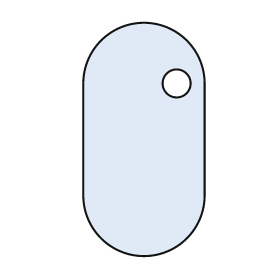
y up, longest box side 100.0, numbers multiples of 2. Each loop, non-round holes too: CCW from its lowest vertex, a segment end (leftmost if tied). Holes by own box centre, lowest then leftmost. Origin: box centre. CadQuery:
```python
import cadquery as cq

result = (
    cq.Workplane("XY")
    .moveTo(-26.0, -24.0)
    .threePointArc((0.0, -50.0), (26.0, -24.0))
    .lineTo(26.0, 24.0)
    .threePointArc((0.0, 50.0), (-26.0, 24.0))
    .close()
    .moveTo(14.0, 24.0)
    .circle(6.0)
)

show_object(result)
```